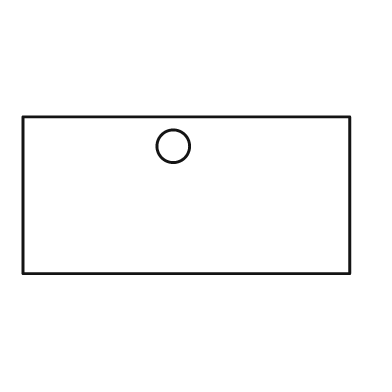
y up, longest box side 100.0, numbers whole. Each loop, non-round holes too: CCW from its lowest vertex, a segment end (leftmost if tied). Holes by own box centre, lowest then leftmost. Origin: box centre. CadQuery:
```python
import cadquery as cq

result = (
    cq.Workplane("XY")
    .moveTo(-50.0, -24.0)
    .lineTo(50.0, -24.0)
    .lineTo(50.0, 24.0)
    .lineTo(-50.0, 24.0)
    .close()
    .moveTo(-4.0, 15.0)
    .circle(5.0)
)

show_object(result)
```